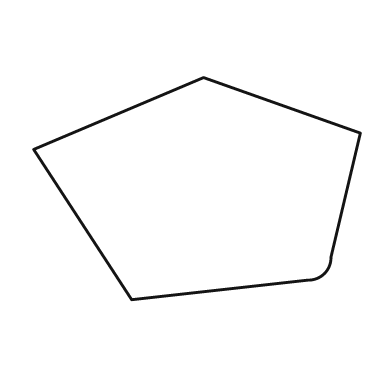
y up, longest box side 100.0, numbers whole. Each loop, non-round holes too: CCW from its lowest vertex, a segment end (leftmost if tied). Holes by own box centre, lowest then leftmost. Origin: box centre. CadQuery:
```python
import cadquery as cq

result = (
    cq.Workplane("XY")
    .moveTo(-20.0, -34.0)
    .lineTo(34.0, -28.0)
    .threePointArc((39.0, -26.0), (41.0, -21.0))
    .lineTo(50.0, 17.0)
    .lineTo(2.0, 34.0)
    .lineTo(-50.0, 12.0)
    .close()
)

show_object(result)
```